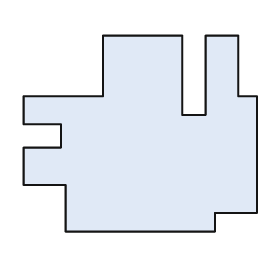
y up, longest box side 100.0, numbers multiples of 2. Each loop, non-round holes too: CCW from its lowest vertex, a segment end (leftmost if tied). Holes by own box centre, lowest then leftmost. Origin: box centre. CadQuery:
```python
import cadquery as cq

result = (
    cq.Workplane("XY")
    .moveTo(-32.0, -42.0)
    .lineTo(32.0, -42.0)
    .lineTo(32.0, -34.0)
    .lineTo(50.0, -34.0)
    .lineTo(50.0, 16.0)
    .lineTo(42.0, 16.0)
    .lineTo(42.0, 42.0)
    .lineTo(28.0, 42.0)
    .lineTo(28.0, 8.0)
    .lineTo(18.0, 8.0)
    .lineTo(18.0, 42.0)
    .lineTo(-16.0, 42.0)
    .lineTo(-16.0, 16.0)
    .lineTo(-50.0, 16.0)
    .lineTo(-50.0, 4.0)
    .lineTo(-34.0, 4.0)
    .lineTo(-34.0, -6.0)
    .lineTo(-50.0, -6.0)
    .lineTo(-50.0, -22.0)
    .lineTo(-32.0, -22.0)
    .close()
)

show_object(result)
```